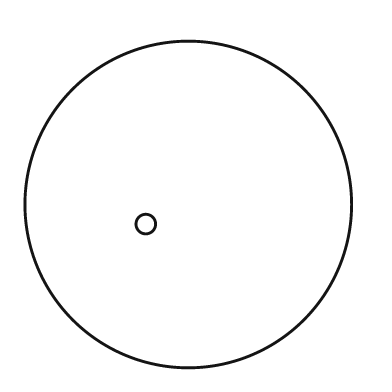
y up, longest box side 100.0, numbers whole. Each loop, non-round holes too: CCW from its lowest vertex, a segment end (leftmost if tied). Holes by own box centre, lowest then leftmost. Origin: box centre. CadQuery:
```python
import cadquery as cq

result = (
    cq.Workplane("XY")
    .moveTo(0.0, 0.0)
    .circle(50.0)
    .moveTo(-13.0, -6.0)
    .circle(3.0)
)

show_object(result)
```